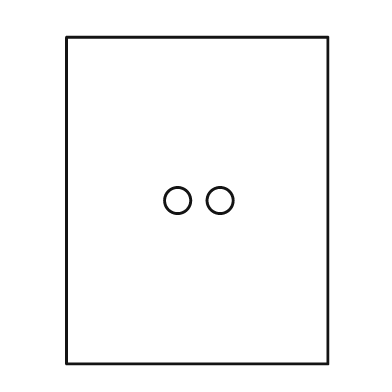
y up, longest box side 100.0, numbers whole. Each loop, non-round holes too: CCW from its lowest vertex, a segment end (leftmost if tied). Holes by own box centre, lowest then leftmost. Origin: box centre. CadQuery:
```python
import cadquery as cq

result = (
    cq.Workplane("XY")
    .moveTo(-40.0, -50.0)
    .lineTo(40.0, -50.0)
    .lineTo(40.0, 50.0)
    .lineTo(-40.0, 50.0)
    .close()
    .moveTo(-6.0, 0.0)
    .circle(4.0)
    .moveTo(7.0, 0.0)
    .circle(4.0)
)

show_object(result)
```